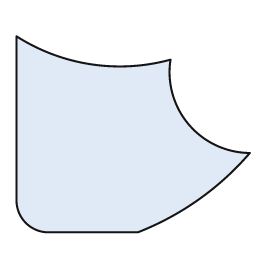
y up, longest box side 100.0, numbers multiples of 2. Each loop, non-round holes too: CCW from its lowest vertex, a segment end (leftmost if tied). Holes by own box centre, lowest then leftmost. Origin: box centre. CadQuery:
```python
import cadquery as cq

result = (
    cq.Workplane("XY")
    .moveTo(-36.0, -42.0)
    .lineTo(2.0, -42.0)
    .threePointArc((28.0, -28.0), (50.0, -8.0))
    .threePointArc((24.0, 4.0), (16.0, 32.0))
    .threePointArc((-18.0, 30.0), (-50.0, 42.0))
    .lineTo(-50.0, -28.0)
    .threePointArc((-46.0, -38.0), (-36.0, -42.0))
    .close()
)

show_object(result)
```